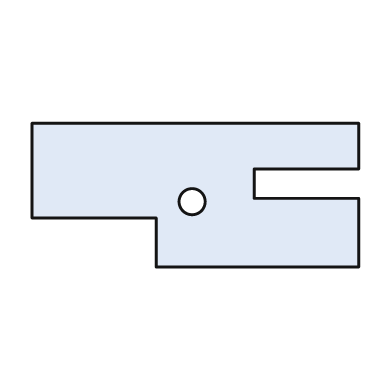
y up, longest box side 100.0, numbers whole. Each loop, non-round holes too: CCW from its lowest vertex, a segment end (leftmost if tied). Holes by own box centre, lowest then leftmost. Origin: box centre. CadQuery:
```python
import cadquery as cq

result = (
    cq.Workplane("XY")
    .moveTo(-12.0, -22.0)
    .lineTo(50.0, -22.0)
    .lineTo(50.0, -1.0)
    .lineTo(18.0, -1.0)
    .lineTo(18.0, 8.0)
    .lineTo(50.0, 8.0)
    .lineTo(50.0, 22.0)
    .lineTo(-50.0, 22.0)
    .lineTo(-50.0, -7.0)
    .lineTo(-12.0, -7.0)
    .close()
    .moveTo(-1.0, -2.0)
    .circle(4.0)
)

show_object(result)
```